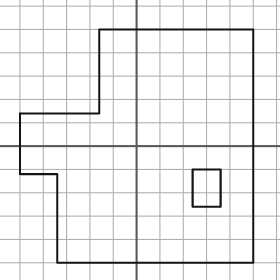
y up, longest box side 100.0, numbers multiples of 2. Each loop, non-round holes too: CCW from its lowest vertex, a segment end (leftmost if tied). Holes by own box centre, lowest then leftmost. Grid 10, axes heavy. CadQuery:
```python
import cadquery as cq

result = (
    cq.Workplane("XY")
    .moveTo(-34.0, -50.0)
    .lineTo(50.0, -50.0)
    .lineTo(50.0, 50.0)
    .lineTo(-16.0, 50.0)
    .lineTo(-16.0, 14.0)
    .lineTo(-50.0, 14.0)
    .lineTo(-50.0, -12.0)
    .lineTo(-34.0, -12.0)
    .close()
    .moveTo(24.0, -26.0)
    .lineTo(36.0, -26.0)
    .lineTo(36.0, -10.0)
    .lineTo(24.0, -10.0)
    .close()
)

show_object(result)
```